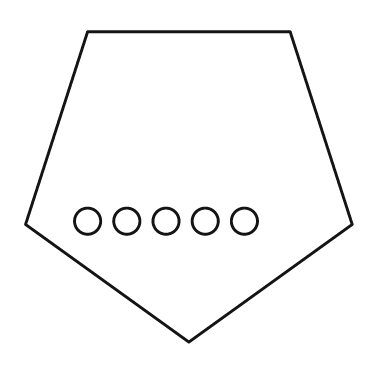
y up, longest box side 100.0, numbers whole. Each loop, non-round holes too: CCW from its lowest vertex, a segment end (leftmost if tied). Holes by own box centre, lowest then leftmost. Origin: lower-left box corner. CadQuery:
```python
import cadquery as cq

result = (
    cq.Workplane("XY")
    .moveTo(50.0, 0.0)
    .lineTo(100.0, 36.0)
    .lineTo(81.0, 95.0)
    .lineTo(19.0, 95.0)
    .lineTo(0.0, 36.0)
    .close()
    .moveTo(19.0, 37.0)
    .circle(4.0)
    .moveTo(31.0, 37.0)
    .circle(4.0)
    .moveTo(43.0, 37.0)
    .circle(4.0)
    .moveTo(55.0, 37.0)
    .circle(4.0)
    .moveTo(67.0, 37.0)
    .circle(4.0)
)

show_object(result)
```